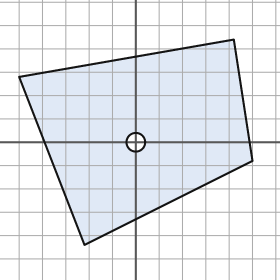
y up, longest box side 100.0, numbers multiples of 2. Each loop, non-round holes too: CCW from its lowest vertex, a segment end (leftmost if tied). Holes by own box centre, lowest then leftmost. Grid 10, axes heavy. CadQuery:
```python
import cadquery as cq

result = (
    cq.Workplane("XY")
    .moveTo(-22.0, -44.0)
    .lineTo(50.0, -8.0)
    .lineTo(42.0, 44.0)
    .lineTo(-50.0, 28.0)
    .close()
    .moveTo(0.0, 0.0)
    .circle(4.0)
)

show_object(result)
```